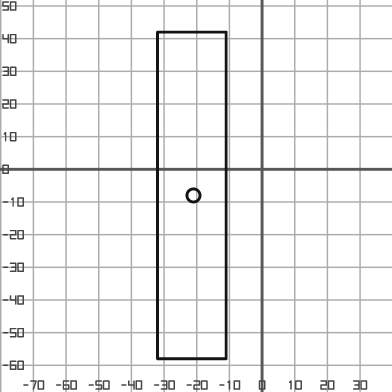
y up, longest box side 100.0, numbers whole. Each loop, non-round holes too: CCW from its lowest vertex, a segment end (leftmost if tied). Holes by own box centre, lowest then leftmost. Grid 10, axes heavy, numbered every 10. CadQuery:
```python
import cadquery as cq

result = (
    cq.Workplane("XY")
    .moveTo(-32.0, -58.0)
    .lineTo(-11.0, -58.0)
    .lineTo(-11.0, 42.0)
    .lineTo(-32.0, 42.0)
    .close()
    .moveTo(-21.0, -8.0)
    .circle(2.0)
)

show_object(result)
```